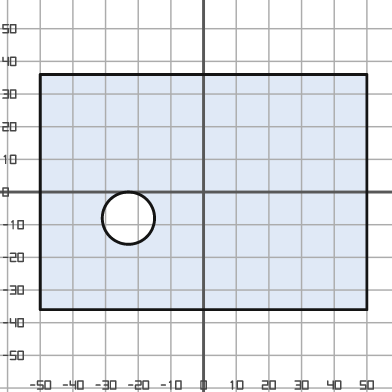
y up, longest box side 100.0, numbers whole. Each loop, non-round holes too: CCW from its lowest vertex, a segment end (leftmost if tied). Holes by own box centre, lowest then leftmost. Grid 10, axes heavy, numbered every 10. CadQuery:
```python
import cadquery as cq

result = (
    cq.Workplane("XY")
    .moveTo(-50.0, -36.0)
    .lineTo(50.0, -36.0)
    .lineTo(50.0, 36.0)
    .lineTo(-50.0, 36.0)
    .close()
    .moveTo(-23.0, -8.0)
    .circle(8.0)
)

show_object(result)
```